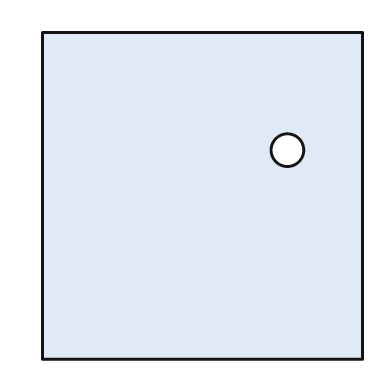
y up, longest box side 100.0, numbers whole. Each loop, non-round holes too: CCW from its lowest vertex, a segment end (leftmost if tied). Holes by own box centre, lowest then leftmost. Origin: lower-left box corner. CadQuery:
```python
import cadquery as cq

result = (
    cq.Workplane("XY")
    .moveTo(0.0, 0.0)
    .lineTo(98.0, 0.0)
    .lineTo(98.0, 100.0)
    .lineTo(0.0, 100.0)
    .close()
    .moveTo(75.0, 64.0)
    .circle(5.0)
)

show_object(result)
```